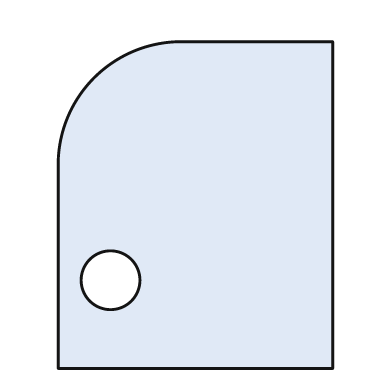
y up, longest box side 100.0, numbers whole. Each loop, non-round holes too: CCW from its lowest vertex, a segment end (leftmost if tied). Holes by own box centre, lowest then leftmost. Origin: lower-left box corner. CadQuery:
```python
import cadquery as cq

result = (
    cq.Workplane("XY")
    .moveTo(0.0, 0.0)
    .lineTo(84.0, 0.0)
    .lineTo(84.0, 100.0)
    .lineTo(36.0, 100.0)
    .threePointArc((11.0, 89.0), (0.0, 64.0))
    .close()
    .moveTo(16.0, 27.0)
    .circle(9.0)
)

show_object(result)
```